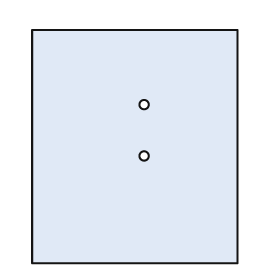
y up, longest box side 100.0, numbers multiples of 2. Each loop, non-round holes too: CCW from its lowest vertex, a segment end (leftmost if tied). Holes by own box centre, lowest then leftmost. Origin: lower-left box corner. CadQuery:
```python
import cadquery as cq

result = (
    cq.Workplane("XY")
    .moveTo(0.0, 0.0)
    .lineTo(88.0, 0.0)
    .lineTo(88.0, 100.0)
    .lineTo(0.0, 100.0)
    .close()
    .moveTo(48.0, 46.0)
    .circle(2.0)
    .moveTo(48.0, 68.0)
    .circle(2.0)
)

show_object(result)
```